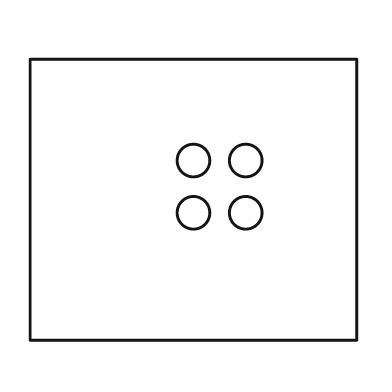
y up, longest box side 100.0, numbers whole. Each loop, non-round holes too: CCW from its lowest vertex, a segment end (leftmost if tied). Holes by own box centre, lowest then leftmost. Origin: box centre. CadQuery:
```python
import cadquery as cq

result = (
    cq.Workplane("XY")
    .moveTo(-50.0, -43.0)
    .lineTo(50.0, -43.0)
    .lineTo(50.0, 43.0)
    .lineTo(-50.0, 43.0)
    .close()
    .moveTo(0.0, -4.0)
    .circle(5.0)
    .moveTo(16.0, -4.0)
    .circle(5.0)
    .moveTo(0.0, 12.0)
    .circle(5.0)
    .moveTo(16.0, 12.0)
    .circle(5.0)
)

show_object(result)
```